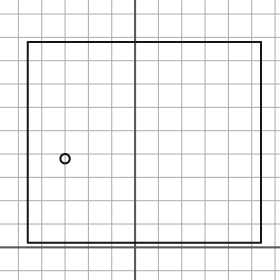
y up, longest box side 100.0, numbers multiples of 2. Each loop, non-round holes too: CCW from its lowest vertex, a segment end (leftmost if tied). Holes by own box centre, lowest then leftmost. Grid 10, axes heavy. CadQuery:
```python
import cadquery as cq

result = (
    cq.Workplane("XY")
    .moveTo(-46.0, 2.0)
    .lineTo(54.0, 2.0)
    .lineTo(54.0, 88.0)
    .lineTo(-46.0, 88.0)
    .close()
    .moveTo(-30.0, 38.0)
    .circle(2.0)
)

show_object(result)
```